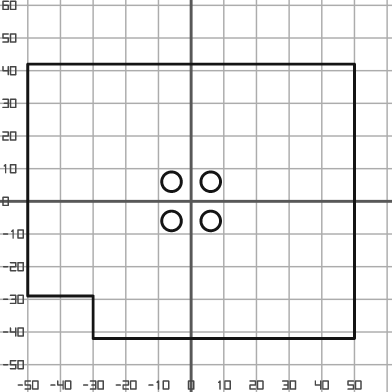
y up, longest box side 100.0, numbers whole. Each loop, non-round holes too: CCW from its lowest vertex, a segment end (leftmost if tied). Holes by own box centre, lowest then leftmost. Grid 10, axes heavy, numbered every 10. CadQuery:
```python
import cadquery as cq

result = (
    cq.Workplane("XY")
    .moveTo(-30.0, -42.0)
    .lineTo(50.0, -42.0)
    .lineTo(50.0, 42.0)
    .lineTo(-50.0, 42.0)
    .lineTo(-50.0, -29.0)
    .lineTo(-30.0, -29.0)
    .close()
    .moveTo(-6.0, -6.0)
    .circle(3.0)
    .moveTo(6.0, -6.0)
    .circle(3.0)
    .moveTo(-6.0, 6.0)
    .circle(3.0)
    .moveTo(6.0, 6.0)
    .circle(3.0)
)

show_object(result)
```